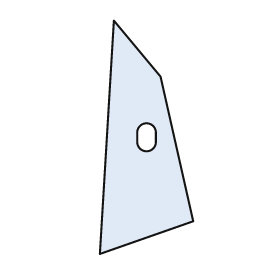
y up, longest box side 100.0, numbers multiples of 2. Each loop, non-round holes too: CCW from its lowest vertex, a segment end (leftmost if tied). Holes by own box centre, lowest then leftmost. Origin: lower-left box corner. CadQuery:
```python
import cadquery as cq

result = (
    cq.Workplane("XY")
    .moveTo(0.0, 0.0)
    .lineTo(40.0, 14.0)
    .lineTo(26.0, 76.0)
    .lineTo(6.0, 100.0)
    .close()
    .moveTo(16.0, 48.0)
    .threePointArc((20.0, 44.0), (24.0, 48.0))
    .lineTo(24.0, 52.0)
    .threePointArc((20.0, 56.0), (16.0, 52.0))
    .close()
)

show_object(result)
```